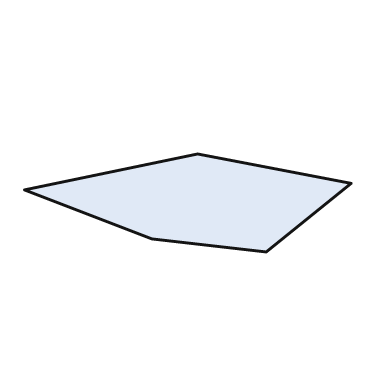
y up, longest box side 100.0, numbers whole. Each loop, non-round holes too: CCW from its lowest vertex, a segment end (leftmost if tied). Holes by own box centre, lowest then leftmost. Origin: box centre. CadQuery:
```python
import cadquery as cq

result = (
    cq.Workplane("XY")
    .moveTo(24.0, -15.0)
    .lineTo(50.0, 6.0)
    .lineTo(3.0, 15.0)
    .lineTo(-50.0, 4.0)
    .lineTo(-11.0, -11.0)
    .close()
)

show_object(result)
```